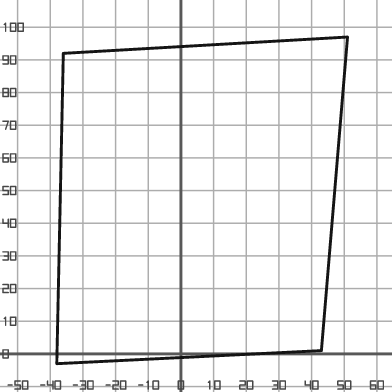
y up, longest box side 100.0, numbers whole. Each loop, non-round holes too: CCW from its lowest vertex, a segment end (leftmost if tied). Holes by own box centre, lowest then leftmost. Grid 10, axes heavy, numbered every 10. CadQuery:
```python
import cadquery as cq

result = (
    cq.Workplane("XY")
    .moveTo(-38.0, -3.0)
    .lineTo(43.0, 1.0)
    .lineTo(51.0, 97.0)
    .lineTo(-36.0, 92.0)
    .close()
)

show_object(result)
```